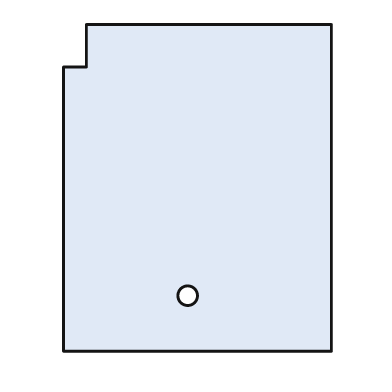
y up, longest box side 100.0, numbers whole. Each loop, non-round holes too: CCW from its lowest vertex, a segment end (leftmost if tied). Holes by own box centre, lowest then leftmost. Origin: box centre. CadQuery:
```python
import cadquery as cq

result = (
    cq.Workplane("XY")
    .moveTo(-41.0, -50.0)
    .lineTo(41.0, -50.0)
    .lineTo(41.0, 50.0)
    .lineTo(-34.0, 50.0)
    .lineTo(-34.0, 37.0)
    .lineTo(-41.0, 37.0)
    .close()
    .moveTo(-3.0, -33.0)
    .circle(3.0)
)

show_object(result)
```